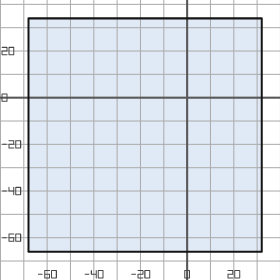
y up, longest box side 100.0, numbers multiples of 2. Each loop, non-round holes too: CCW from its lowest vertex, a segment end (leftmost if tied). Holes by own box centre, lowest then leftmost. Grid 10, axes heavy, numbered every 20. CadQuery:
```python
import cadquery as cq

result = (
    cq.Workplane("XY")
    .moveTo(-68.0, -66.0)
    .lineTo(32.0, -66.0)
    .lineTo(32.0, 34.0)
    .lineTo(-68.0, 34.0)
    .close()
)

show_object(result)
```